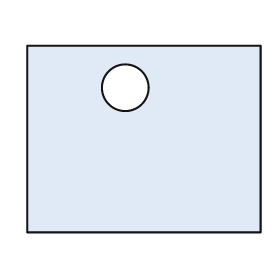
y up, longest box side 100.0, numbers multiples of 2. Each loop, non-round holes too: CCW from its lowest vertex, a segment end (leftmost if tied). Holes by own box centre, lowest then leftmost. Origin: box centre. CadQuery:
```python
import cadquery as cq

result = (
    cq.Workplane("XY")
    .moveTo(-50.0, -40.0)
    .lineTo(50.0, -40.0)
    .lineTo(50.0, 40.0)
    .lineTo(-50.0, 40.0)
    .close()
    .moveTo(-8.0, 22.0)
    .circle(10.0)
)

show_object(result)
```